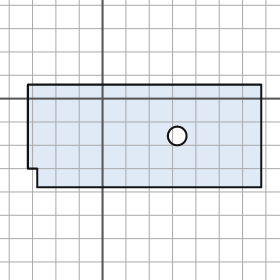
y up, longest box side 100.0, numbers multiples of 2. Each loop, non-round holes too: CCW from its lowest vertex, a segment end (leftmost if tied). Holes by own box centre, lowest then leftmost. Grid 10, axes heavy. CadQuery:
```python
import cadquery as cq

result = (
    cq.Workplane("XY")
    .moveTo(-28.0, -38.0)
    .lineTo(68.0, -38.0)
    .lineTo(68.0, 6.0)
    .lineTo(-32.0, 6.0)
    .lineTo(-32.0, -30.0)
    .lineTo(-28.0, -30.0)
    .close()
    .moveTo(32.0, -16.0)
    .circle(4.0)
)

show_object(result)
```